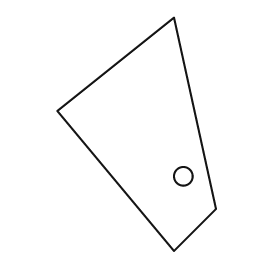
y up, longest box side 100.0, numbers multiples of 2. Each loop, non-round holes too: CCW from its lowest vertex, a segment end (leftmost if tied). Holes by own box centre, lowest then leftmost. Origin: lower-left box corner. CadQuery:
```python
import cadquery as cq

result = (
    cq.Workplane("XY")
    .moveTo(50.0, 0.0)
    .lineTo(68.0, 18.0)
    .lineTo(50.0, 100.0)
    .lineTo(0.0, 60.0)
    .close()
    .moveTo(54.0, 32.0)
    .circle(4.0)
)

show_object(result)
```